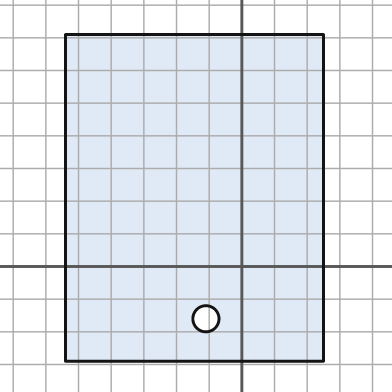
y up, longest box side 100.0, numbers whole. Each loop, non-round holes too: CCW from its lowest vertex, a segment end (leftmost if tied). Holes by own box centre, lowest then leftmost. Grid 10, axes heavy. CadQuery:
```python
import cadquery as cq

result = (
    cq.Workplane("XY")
    .moveTo(-54.0, -29.0)
    .lineTo(25.0, -29.0)
    .lineTo(25.0, 71.0)
    .lineTo(-54.0, 71.0)
    .close()
    .moveTo(-11.0, -16.0)
    .circle(4.0)
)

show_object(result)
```